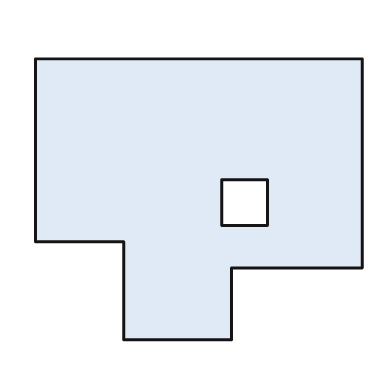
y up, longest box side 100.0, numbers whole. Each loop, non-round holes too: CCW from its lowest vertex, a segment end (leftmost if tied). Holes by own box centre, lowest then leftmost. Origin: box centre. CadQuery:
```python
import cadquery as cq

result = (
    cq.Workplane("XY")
    .moveTo(-23.0, -43.0)
    .lineTo(10.0, -43.0)
    .lineTo(10.0, -21.0)
    .lineTo(50.0, -21.0)
    .lineTo(50.0, 43.0)
    .lineTo(-50.0, 43.0)
    .lineTo(-50.0, -13.0)
    .lineTo(-23.0, -13.0)
    .close()
    .moveTo(7.0, -8.0)
    .lineTo(21.0, -8.0)
    .lineTo(21.0, 6.0)
    .lineTo(7.0, 6.0)
    .close()
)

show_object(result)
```